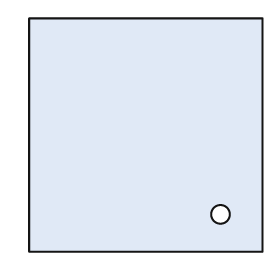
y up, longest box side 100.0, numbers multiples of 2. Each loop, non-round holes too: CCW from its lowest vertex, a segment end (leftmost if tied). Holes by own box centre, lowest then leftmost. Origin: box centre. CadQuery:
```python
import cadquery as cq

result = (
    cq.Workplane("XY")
    .moveTo(-50.0, -50.0)
    .lineTo(50.0, -50.0)
    .lineTo(50.0, 50.0)
    .lineTo(-50.0, 50.0)
    .close()
    .moveTo(32.0, -34.0)
    .circle(4.0)
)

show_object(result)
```